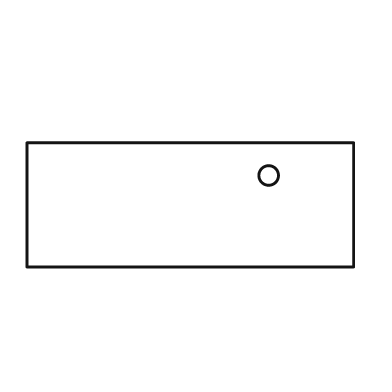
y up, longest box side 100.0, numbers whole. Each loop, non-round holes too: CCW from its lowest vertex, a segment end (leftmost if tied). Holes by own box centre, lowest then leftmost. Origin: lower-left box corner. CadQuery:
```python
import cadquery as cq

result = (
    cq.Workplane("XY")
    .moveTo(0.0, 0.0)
    .lineTo(100.0, 0.0)
    .lineTo(100.0, 38.0)
    .lineTo(0.0, 38.0)
    .close()
    .moveTo(74.0, 28.0)
    .circle(3.0)
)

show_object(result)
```